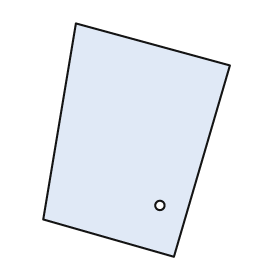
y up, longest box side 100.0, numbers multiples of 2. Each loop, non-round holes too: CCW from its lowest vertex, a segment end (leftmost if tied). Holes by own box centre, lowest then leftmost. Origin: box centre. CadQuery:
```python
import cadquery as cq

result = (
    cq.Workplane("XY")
    .moveTo(16.0, -50.0)
    .lineTo(40.0, 32.0)
    .lineTo(-26.0, 50.0)
    .lineTo(-40.0, -34.0)
    .close()
    .moveTo(10.0, -28.0)
    .circle(2.0)
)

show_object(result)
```